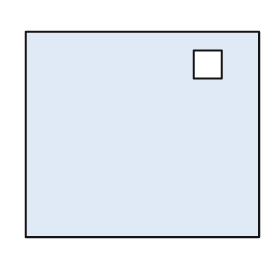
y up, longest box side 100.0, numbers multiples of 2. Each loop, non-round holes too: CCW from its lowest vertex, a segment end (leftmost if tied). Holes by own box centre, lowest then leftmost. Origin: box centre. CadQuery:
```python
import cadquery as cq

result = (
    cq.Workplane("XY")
    .moveTo(-50.0, -44.0)
    .lineTo(50.0, -44.0)
    .lineTo(50.0, 44.0)
    .lineTo(-50.0, 44.0)
    .close()
    .moveTo(22.0, 24.0)
    .lineTo(34.0, 24.0)
    .lineTo(34.0, 36.0)
    .lineTo(22.0, 36.0)
    .close()
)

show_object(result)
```